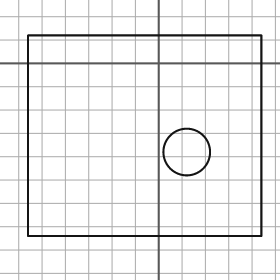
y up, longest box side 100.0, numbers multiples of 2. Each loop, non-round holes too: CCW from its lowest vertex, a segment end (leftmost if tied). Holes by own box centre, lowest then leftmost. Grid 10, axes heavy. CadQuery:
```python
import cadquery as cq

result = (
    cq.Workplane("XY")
    .moveTo(-56.0, -74.0)
    .lineTo(44.0, -74.0)
    .lineTo(44.0, 12.0)
    .lineTo(-56.0, 12.0)
    .close()
    .moveTo(12.0, -38.0)
    .circle(10.0)
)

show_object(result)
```